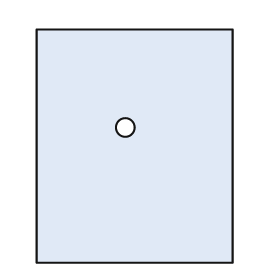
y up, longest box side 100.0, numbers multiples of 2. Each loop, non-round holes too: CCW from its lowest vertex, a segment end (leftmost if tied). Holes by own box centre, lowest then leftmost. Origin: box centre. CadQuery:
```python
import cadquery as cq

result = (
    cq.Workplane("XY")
    .moveTo(-42.0, -50.0)
    .lineTo(42.0, -50.0)
    .lineTo(42.0, 50.0)
    .lineTo(-42.0, 50.0)
    .close()
    .moveTo(-4.0, 8.0)
    .circle(4.0)
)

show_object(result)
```